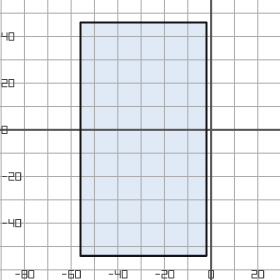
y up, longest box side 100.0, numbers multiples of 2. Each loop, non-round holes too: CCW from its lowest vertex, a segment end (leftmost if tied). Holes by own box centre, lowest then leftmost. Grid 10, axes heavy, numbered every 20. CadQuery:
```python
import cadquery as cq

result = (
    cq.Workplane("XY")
    .moveTo(-56.0, -54.0)
    .lineTo(-2.0, -54.0)
    .lineTo(-2.0, 46.0)
    .lineTo(-56.0, 46.0)
    .close()
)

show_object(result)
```